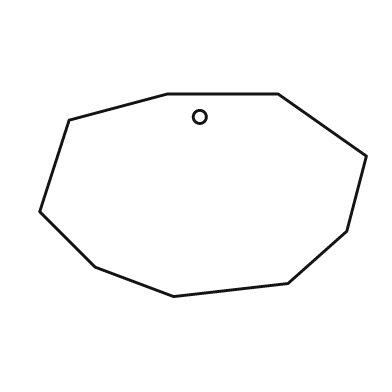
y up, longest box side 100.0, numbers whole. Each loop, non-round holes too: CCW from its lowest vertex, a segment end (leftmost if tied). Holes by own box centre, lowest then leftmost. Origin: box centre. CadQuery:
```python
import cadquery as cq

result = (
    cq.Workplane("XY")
    .moveTo(-9.0, -31.0)
    .lineTo(26.0, -27.0)
    .lineTo(44.0, -11.0)
    .lineTo(50.0, 12.0)
    .lineTo(23.0, 31.0)
    .lineTo(-11.0, 31.0)
    .lineTo(-41.0, 23.0)
    .lineTo(-50.0, -5.0)
    .lineTo(-33.0, -22.0)
    .close()
    .moveTo(-1.0, 24.0)
    .circle(2.0)
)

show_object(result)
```